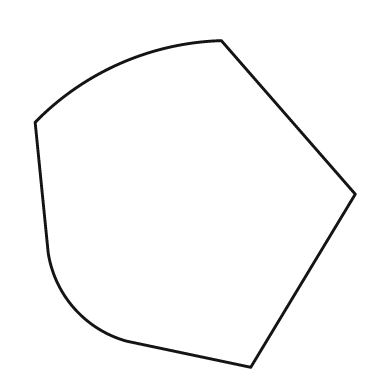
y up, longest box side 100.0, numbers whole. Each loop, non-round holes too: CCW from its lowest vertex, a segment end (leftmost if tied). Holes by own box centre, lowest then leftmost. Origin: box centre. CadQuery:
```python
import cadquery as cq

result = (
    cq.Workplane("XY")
    .moveTo(17.0, -50.0)
    .lineTo(49.0, 3.0)
    .lineTo(8.0, 50.0)
    .threePointArc((-23.0, 43.0), (-49.0, 25.0))
    .lineTo(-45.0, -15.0)
    .threePointArc((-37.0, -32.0), (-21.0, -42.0))
    .close()
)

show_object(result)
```